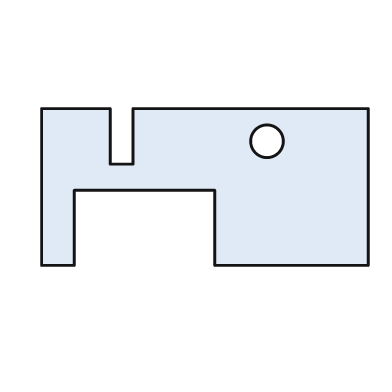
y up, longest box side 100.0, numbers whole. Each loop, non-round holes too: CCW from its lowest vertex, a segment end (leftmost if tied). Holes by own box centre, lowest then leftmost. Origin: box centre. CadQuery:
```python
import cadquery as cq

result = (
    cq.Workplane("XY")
    .moveTo(-50.0, -24.0)
    .lineTo(-40.0, -24.0)
    .lineTo(-40.0, -1.0)
    .lineTo(3.0, -1.0)
    .lineTo(3.0, -24.0)
    .lineTo(50.0, -24.0)
    .lineTo(50.0, 24.0)
    .lineTo(-22.0, 24.0)
    .lineTo(-22.0, 7.0)
    .lineTo(-29.0, 7.0)
    .lineTo(-29.0, 24.0)
    .lineTo(-50.0, 24.0)
    .close()
    .moveTo(19.0, 14.0)
    .circle(5.0)
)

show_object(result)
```